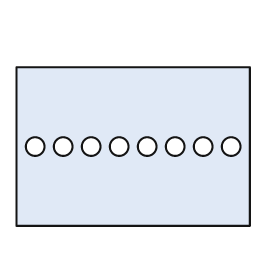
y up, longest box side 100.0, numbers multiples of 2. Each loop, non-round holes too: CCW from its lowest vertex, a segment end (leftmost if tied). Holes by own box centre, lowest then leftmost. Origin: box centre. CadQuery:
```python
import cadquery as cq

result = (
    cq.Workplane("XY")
    .moveTo(-50.0, -34.0)
    .lineTo(50.0, -34.0)
    .lineTo(50.0, 34.0)
    .lineTo(-50.0, 34.0)
    .close()
    .moveTo(-42.0, 0.0)
    .circle(4.0)
    .moveTo(-30.0, 0.0)
    .circle(4.0)
    .moveTo(-18.0, 0.0)
    .circle(4.0)
    .moveTo(-6.0, 0.0)
    .circle(4.0)
    .moveTo(6.0, 0.0)
    .circle(4.0)
    .moveTo(18.0, 0.0)
    .circle(4.0)
    .moveTo(30.0, 0.0)
    .circle(4.0)
    .moveTo(42.0, 0.0)
    .circle(4.0)
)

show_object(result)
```